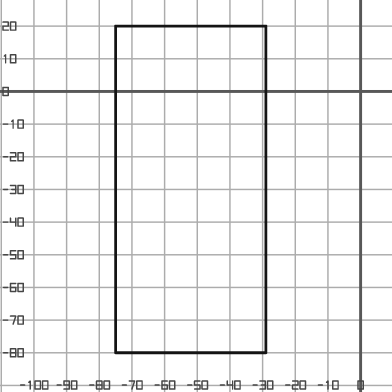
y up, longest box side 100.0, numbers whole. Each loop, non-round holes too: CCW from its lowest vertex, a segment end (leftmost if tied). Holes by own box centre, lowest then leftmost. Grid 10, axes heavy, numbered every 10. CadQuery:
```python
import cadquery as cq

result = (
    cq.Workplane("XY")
    .moveTo(-75.0, -80.0)
    .lineTo(-29.0, -80.0)
    .lineTo(-29.0, 20.0)
    .lineTo(-75.0, 20.0)
    .close()
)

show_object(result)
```